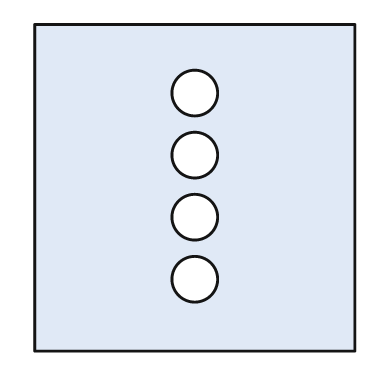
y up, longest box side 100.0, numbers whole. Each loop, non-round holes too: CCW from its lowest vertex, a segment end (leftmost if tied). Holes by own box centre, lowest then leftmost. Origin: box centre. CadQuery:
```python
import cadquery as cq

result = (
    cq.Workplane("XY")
    .moveTo(-49.0, -50.0)
    .lineTo(49.0, -50.0)
    .lineTo(49.0, 50.0)
    .lineTo(-49.0, 50.0)
    .close()
    .moveTo(0.0, -28.0)
    .circle(7.0)
    .moveTo(0.0, -9.0)
    .circle(7.0)
    .moveTo(0.0, 10.0)
    .circle(7.0)
    .moveTo(0.0, 29.0)
    .circle(7.0)
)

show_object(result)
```